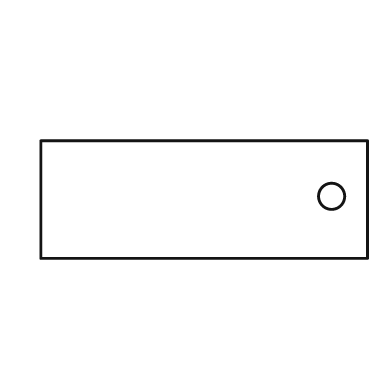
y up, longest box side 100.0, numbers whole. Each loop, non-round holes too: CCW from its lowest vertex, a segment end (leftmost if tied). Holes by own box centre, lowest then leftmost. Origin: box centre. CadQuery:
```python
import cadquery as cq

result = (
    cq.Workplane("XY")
    .moveTo(-50.0, -18.0)
    .lineTo(50.0, -18.0)
    .lineTo(50.0, 18.0)
    .lineTo(-50.0, 18.0)
    .close()
    .moveTo(39.0, 1.0)
    .circle(4.0)
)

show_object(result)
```